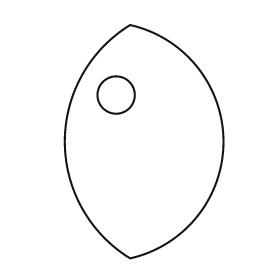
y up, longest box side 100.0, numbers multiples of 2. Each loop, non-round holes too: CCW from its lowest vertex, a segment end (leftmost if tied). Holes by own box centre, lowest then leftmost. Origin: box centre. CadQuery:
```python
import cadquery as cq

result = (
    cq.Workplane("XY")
    .moveTo(-6.0, -50.0)
    .threePointArc((34.0, 0.0), (-6.0, 50.0))
    .threePointArc((-34.0, 0.0), (-6.0, -50.0))
    .close()
    .moveTo(-12.0, 20.0)
    .circle(8.0)
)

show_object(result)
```